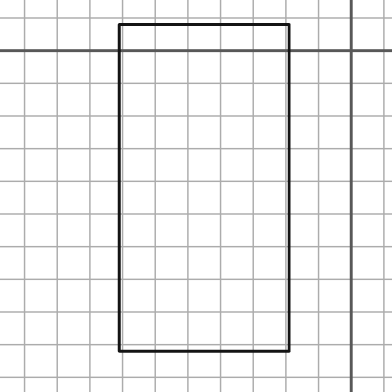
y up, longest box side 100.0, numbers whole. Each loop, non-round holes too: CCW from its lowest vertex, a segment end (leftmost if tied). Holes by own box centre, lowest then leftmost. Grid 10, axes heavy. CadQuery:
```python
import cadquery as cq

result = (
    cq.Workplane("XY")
    .moveTo(-71.0, -92.0)
    .lineTo(-19.0, -92.0)
    .lineTo(-19.0, 8.0)
    .lineTo(-71.0, 8.0)
    .close()
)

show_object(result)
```